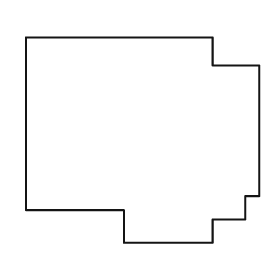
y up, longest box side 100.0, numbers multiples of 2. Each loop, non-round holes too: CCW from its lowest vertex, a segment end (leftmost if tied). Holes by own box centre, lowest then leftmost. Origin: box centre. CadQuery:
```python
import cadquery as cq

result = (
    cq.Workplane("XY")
    .moveTo(-8.0, -44.0)
    .lineTo(30.0, -44.0)
    .lineTo(30.0, -34.0)
    .lineTo(44.0, -34.0)
    .lineTo(44.0, -24.0)
    .lineTo(50.0, -24.0)
    .lineTo(50.0, 32.0)
    .lineTo(30.0, 32.0)
    .lineTo(30.0, 44.0)
    .lineTo(-50.0, 44.0)
    .lineTo(-50.0, -30.0)
    .lineTo(-8.0, -30.0)
    .close()
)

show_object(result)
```